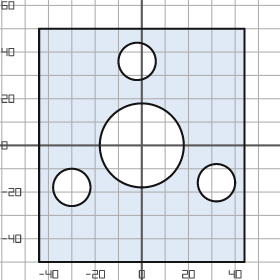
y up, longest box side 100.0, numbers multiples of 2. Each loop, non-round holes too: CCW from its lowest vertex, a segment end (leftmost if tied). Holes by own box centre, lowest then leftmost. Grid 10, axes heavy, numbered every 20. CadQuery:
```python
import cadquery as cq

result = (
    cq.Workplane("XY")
    .moveTo(-44.0, -50.0)
    .lineTo(44.0, -50.0)
    .lineTo(44.0, 50.0)
    .lineTo(-44.0, 50.0)
    .close()
    .moveTo(-30.0, -18.0)
    .circle(8.0)
    .moveTo(32.0, -16.0)
    .circle(8.0)
    .moveTo(0.0, 0.0)
    .circle(18.0)
    .moveTo(-2.0, 36.0)
    .circle(8.0)
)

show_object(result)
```